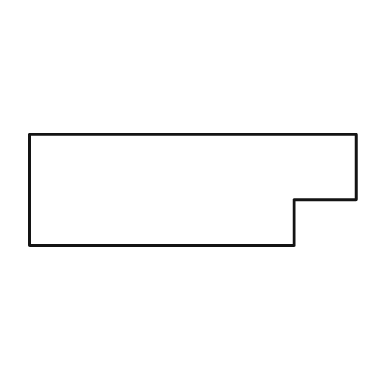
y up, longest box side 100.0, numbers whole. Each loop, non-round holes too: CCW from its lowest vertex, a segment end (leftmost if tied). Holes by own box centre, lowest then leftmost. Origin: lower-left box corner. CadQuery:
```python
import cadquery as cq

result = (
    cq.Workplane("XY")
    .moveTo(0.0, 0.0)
    .lineTo(81.0, 0.0)
    .lineTo(81.0, 14.0)
    .lineTo(100.0, 14.0)
    .lineTo(100.0, 34.0)
    .lineTo(0.0, 34.0)
    .close()
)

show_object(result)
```